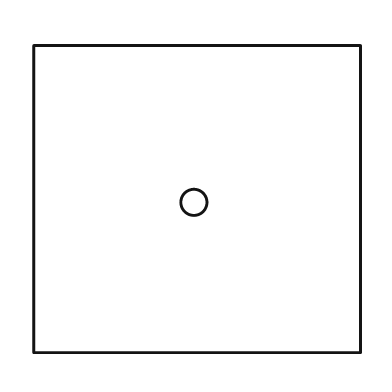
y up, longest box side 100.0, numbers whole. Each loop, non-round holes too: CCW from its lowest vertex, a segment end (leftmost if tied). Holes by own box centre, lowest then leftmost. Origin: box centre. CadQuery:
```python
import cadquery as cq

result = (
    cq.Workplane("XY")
    .moveTo(-50.0, -47.0)
    .lineTo(50.0, -47.0)
    .lineTo(50.0, 47.0)
    .lineTo(-50.0, 47.0)
    .close()
    .moveTo(-1.0, -1.0)
    .circle(4.0)
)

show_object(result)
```